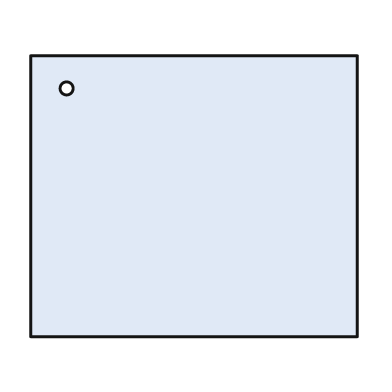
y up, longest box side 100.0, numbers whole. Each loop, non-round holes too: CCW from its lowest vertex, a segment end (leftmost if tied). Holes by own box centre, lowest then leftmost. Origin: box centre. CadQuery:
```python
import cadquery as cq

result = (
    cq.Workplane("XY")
    .moveTo(-50.0, -43.0)
    .lineTo(50.0, -43.0)
    .lineTo(50.0, 43.0)
    .lineTo(-50.0, 43.0)
    .close()
    .moveTo(-39.0, 33.0)
    .circle(2.0)
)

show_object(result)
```